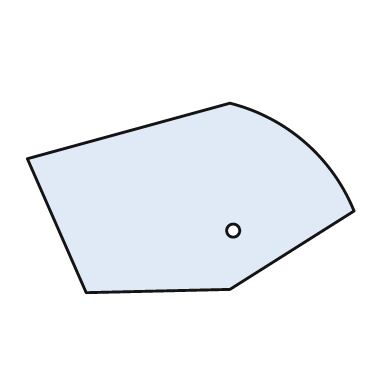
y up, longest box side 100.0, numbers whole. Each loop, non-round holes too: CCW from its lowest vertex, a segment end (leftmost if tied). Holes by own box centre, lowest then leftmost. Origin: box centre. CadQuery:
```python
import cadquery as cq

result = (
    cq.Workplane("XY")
    .moveTo(-32.0, -29.0)
    .lineTo(12.0, -28.0)
    .lineTo(50.0, -4.0)
    .threePointArc((35.0, 17.0), (12.0, 29.0))
    .lineTo(-50.0, 12.0)
    .close()
    .moveTo(13.0, -10.0)
    .circle(2.0)
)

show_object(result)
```